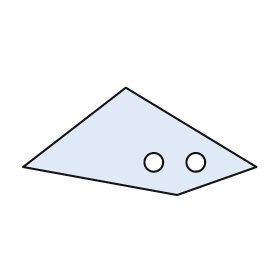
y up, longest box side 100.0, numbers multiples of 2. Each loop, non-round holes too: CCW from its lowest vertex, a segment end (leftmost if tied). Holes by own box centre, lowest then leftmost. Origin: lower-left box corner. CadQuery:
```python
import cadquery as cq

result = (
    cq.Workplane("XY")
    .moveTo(66.0, 0.0)
    .lineTo(100.0, 12.0)
    .lineTo(44.0, 46.0)
    .lineTo(0.0, 12.0)
    .close()
    .moveTo(56.0, 14.0)
    .circle(4.0)
    .moveTo(74.0, 14.0)
    .circle(4.0)
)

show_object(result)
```